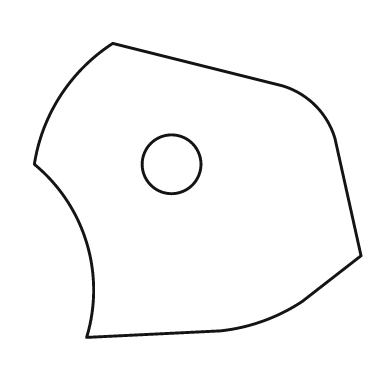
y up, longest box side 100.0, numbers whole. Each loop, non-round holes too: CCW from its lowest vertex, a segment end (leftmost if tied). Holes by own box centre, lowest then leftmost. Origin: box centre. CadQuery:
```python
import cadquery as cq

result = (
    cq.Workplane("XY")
    .moveTo(-34.0, -45.0)
    .lineTo(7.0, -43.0)
    .threePointArc((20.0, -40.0), (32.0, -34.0))
    .lineTo(50.0, -20.0)
    .lineTo(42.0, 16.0)
    .threePointArc((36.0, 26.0), (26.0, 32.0))
    .lineTo(-26.0, 45.0)
    .threePointArc((-42.0, 29.0), (-50.0, 8.0))
    .threePointArc((-34.0, -16.0), (-34.0, -45.0))
    .close()
    .moveTo(-8.0, 8.0)
    .circle(9.0)
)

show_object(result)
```